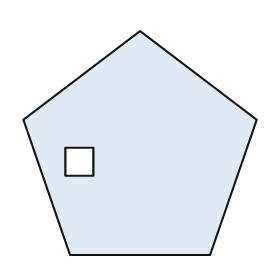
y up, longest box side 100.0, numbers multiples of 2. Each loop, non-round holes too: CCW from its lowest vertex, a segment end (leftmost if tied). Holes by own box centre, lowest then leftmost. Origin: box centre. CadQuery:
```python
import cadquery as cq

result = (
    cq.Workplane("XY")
    .moveTo(-30.0, -48.0)
    .lineTo(30.0, -48.0)
    .lineTo(50.0, 10.0)
    .lineTo(0.0, 48.0)
    .lineTo(-50.0, 10.0)
    .close()
    .moveTo(-32.0, -14.0)
    .lineTo(-20.0, -14.0)
    .lineTo(-20.0, -2.0)
    .lineTo(-32.0, -2.0)
    .close()
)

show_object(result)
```